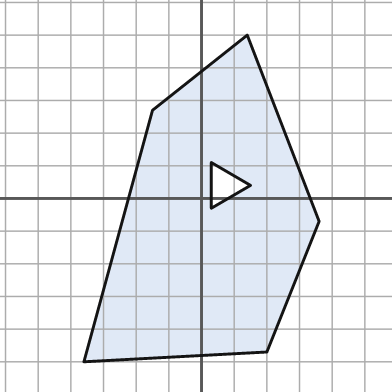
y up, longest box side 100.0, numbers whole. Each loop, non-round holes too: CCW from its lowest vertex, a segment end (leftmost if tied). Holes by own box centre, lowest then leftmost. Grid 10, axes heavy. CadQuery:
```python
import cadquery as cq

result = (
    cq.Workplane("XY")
    .moveTo(-36.0, -50.0)
    .lineTo(20.0, -47.0)
    .lineTo(36.0, -7.0)
    .lineTo(14.0, 50.0)
    .lineTo(-15.0, 27.0)
    .close()
    .moveTo(3.0, -3.0)
    .lineTo(15.0, 4.0)
    .lineTo(3.0, 11.0)
    .close()
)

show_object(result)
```